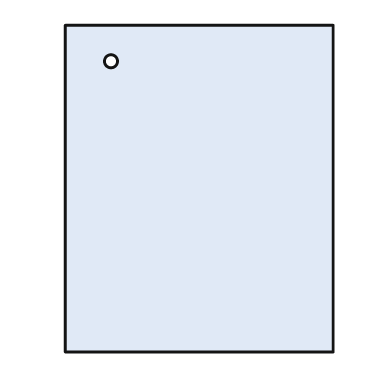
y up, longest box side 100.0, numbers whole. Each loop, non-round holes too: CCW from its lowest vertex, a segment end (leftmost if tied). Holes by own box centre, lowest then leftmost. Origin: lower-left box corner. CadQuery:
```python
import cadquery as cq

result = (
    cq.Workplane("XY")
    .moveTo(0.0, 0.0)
    .lineTo(82.0, 0.0)
    .lineTo(82.0, 100.0)
    .lineTo(0.0, 100.0)
    .close()
    .moveTo(14.0, 89.0)
    .circle(2.0)
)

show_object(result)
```